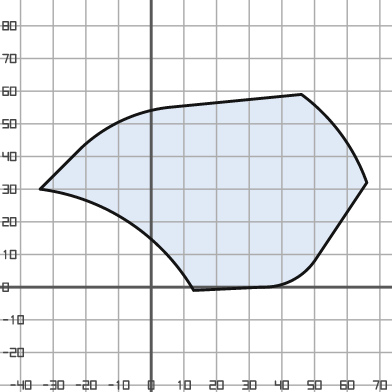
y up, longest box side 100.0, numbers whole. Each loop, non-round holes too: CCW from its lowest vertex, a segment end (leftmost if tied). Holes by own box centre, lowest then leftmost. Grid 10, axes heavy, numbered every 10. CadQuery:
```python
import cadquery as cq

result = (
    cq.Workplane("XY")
    .moveTo(13.0, -1.0)
    .lineTo(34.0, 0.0)
    .threePointArc((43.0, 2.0), (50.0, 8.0))
    .lineTo(66.0, 32.0)
    .threePointArc((58.0, 47.0), (46.0, 59.0))
    .lineTo(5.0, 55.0)
    .threePointArc((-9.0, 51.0), (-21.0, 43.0))
    .lineTo(-34.0, 30.0)
    .threePointArc((-7.0, 20.0), (13.0, -1.0))
    .close()
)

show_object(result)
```